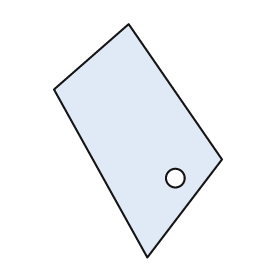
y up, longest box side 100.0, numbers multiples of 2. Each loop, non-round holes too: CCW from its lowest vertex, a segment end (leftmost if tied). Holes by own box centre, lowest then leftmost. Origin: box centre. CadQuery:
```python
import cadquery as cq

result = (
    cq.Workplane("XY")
    .moveTo(4.0, -50.0)
    .lineTo(36.0, -8.0)
    .lineTo(-4.0, 50.0)
    .lineTo(-36.0, 22.0)
    .close()
    .moveTo(16.0, -16.0)
    .circle(4.0)
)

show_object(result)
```